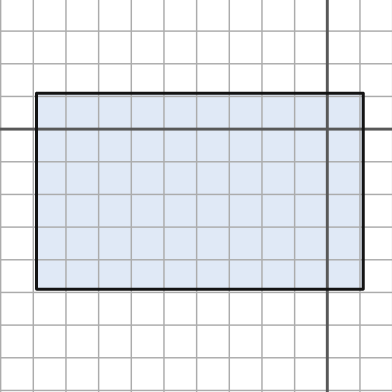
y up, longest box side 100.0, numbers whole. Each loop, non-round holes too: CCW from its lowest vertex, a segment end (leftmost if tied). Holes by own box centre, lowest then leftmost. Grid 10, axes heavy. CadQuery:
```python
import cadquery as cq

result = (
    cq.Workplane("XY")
    .moveTo(-89.0, -49.0)
    .lineTo(11.0, -49.0)
    .lineTo(11.0, 11.0)
    .lineTo(-89.0, 11.0)
    .close()
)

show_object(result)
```